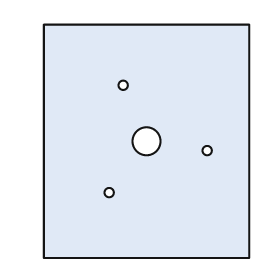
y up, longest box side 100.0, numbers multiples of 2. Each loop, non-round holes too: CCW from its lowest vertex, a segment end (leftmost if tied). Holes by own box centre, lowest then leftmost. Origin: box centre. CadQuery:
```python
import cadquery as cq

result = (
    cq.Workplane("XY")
    .moveTo(-44.0, -50.0)
    .lineTo(44.0, -50.0)
    .lineTo(44.0, 50.0)
    .lineTo(-44.0, 50.0)
    .close()
    .moveTo(-16.0, -22.0)
    .circle(2.0)
    .moveTo(26.0, -4.0)
    .circle(2.0)
    .moveTo(0.0, 0.0)
    .circle(6.0)
    .moveTo(-10.0, 24.0)
    .circle(2.0)
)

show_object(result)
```